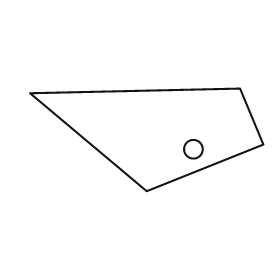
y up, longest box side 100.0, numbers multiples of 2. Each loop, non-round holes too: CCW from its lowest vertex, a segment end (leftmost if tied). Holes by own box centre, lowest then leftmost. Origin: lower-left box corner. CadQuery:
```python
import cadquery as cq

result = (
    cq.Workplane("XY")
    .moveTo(50.0, 0.0)
    .lineTo(100.0, 20.0)
    .lineTo(90.0, 44.0)
    .lineTo(0.0, 42.0)
    .close()
    .moveTo(70.0, 18.0)
    .circle(4.0)
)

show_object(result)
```